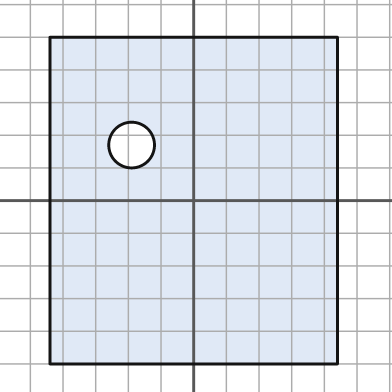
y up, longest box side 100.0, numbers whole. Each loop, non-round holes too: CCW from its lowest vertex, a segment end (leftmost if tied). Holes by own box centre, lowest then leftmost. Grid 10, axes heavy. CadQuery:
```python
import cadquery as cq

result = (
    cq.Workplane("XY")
    .moveTo(-44.0, -50.0)
    .lineTo(44.0, -50.0)
    .lineTo(44.0, 50.0)
    .lineTo(-44.0, 50.0)
    .close()
    .moveTo(-19.0, 17.0)
    .circle(7.0)
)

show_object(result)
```